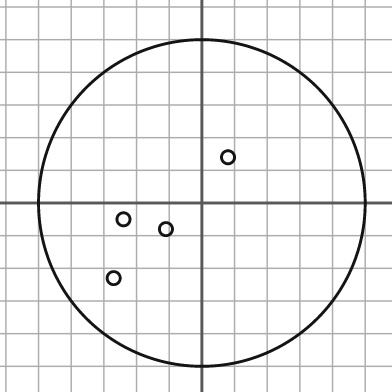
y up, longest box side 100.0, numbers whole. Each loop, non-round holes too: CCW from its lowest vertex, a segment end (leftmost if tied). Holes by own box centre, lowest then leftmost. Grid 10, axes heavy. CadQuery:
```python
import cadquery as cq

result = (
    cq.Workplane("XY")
    .moveTo(0.0, 0.0)
    .circle(50.0)
    .moveTo(-27.0, -23.0)
    .circle(2.0)
    .moveTo(-11.0, -8.0)
    .circle(2.0)
    .moveTo(-24.0, -5.0)
    .circle(2.0)
    .moveTo(8.0, 14.0)
    .circle(2.0)
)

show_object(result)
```